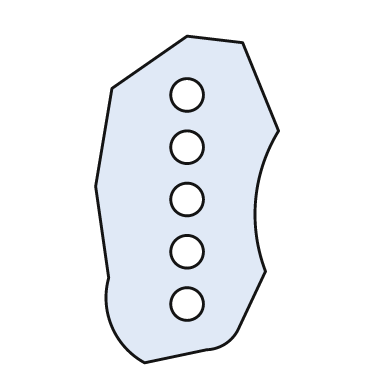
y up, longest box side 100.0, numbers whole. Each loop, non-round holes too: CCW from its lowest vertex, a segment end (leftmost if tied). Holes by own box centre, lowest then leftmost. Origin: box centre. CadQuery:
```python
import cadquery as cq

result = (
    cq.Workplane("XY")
    .moveTo(-13.0, -50.0)
    .lineTo(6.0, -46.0)
    .threePointArc((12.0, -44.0), (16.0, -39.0))
    .lineTo(24.0, -22.0)
    .threePointArc((21.0, 0.0), (28.0, 21.0))
    .lineTo(17.0, 48.0)
    .lineTo(0.0, 50.0)
    .lineTo(-23.0, 34.0)
    .lineTo(-28.0, 4.0)
    .lineTo(-24.0, -24.0)
    .threePointArc((-23.0, -39.0), (-13.0, -50.0))
    .close()
    .moveTo(0.0, -32.0)
    .circle(5.0)
    .moveTo(0.0, -16.0)
    .circle(5.0)
    .moveTo(0.0, 0.0)
    .circle(5.0)
    .moveTo(0.0, 16.0)
    .circle(5.0)
    .moveTo(0.0, 32.0)
    .circle(5.0)
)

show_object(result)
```